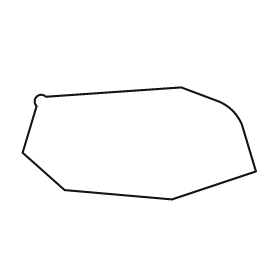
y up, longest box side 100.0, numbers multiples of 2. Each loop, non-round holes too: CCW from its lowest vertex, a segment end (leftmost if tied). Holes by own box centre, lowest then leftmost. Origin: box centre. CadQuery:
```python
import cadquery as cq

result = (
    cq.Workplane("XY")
    .moveTo(14.0, -24.0)
    .lineTo(50.0, -12.0)
    .lineTo(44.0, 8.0)
    .threePointArc((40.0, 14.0), (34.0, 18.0))
    .lineTo(18.0, 24.0)
    .lineTo(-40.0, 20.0)
    .threePointArc((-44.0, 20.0), (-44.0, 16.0))
    .lineTo(-50.0, -4.0)
    .lineTo(-32.0, -20.0)
    .close()
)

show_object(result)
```